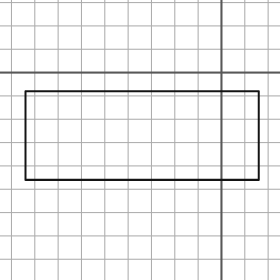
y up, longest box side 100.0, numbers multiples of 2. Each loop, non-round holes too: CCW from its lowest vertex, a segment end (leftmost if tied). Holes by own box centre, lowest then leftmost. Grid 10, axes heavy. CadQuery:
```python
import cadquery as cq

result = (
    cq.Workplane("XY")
    .moveTo(-84.0, -46.0)
    .lineTo(16.0, -46.0)
    .lineTo(16.0, -8.0)
    .lineTo(-84.0, -8.0)
    .close()
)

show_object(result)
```